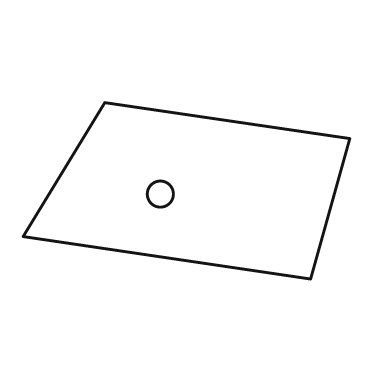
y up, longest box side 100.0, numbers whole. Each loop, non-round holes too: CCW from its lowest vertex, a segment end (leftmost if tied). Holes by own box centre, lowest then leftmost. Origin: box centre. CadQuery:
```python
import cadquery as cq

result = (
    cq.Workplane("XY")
    .moveTo(38.0, -27.0)
    .lineTo(50.0, 16.0)
    .lineTo(-25.0, 27.0)
    .lineTo(-50.0, -14.0)
    .close()
    .moveTo(-8.0, -1.0)
    .circle(4.0)
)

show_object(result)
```